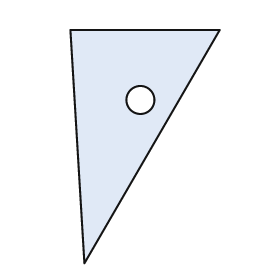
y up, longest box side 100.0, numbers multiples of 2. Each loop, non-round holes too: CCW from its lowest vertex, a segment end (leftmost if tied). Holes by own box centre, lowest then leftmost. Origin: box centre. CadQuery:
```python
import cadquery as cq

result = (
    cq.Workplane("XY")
    .moveTo(-26.0, -50.0)
    .lineTo(32.0, 50.0)
    .lineTo(-32.0, 50.0)
    .close()
    .moveTo(-2.0, 20.0)
    .circle(6.0)
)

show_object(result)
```